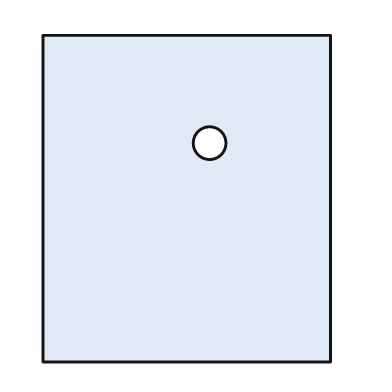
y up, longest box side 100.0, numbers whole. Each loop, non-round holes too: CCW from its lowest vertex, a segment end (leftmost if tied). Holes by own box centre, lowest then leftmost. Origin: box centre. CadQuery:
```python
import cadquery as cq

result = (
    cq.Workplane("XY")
    .moveTo(-44.0, -50.0)
    .lineTo(44.0, -50.0)
    .lineTo(44.0, 50.0)
    .lineTo(-44.0, 50.0)
    .close()
    .moveTo(7.0, 17.0)
    .circle(5.0)
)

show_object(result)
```